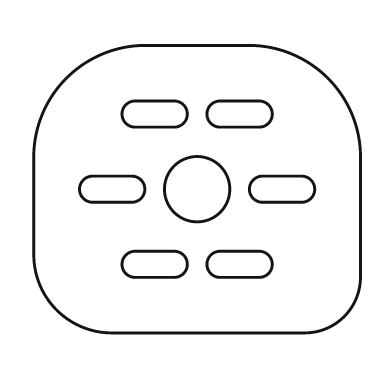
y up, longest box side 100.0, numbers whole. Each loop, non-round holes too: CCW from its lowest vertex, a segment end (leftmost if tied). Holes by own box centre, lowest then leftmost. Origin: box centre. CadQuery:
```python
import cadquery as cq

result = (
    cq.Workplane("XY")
    .moveTo(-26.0, -44.0)
    .lineTo(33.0, -44.0)
    .threePointArc((45.0, -39.0), (50.0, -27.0))
    .lineTo(50.0, 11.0)
    .threePointArc((40.0, 34.0), (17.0, 44.0))
    .lineTo(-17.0, 44.0)
    .threePointArc((-40.0, 34.0), (-50.0, 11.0))
    .lineTo(-50.0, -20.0)
    .threePointArc((-43.0, -37.0), (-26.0, -44.0))
    .close()
    .moveTo(-19.0, -27.0)
    .lineTo(-7.0, -27.0)
    .threePointArc((-3.0, -23.0), (-7.0, -19.0))
    .lineTo(-19.0, -19.0)
    .threePointArc((-23.0, -23.0), (-19.0, -27.0))
    .close()
    .moveTo(7.0, -27.0)
    .lineTo(19.0, -27.0)
    .threePointArc((23.0, -23.0), (19.0, -19.0))
    .lineTo(7.0, -19.0)
    .threePointArc((3.0, -23.0), (7.0, -27.0))
    .close()
    .moveTo(-32.0, -4.0)
    .lineTo(-20.0, -4.0)
    .threePointArc((-16.0, 0.0), (-20.0, 4.0))
    .lineTo(-32.0, 4.0)
    .threePointArc((-36.0, 0.0), (-32.0, -4.0))
    .close()
    .moveTo(0.0, 0.0)
    .circle(10.0)
    .moveTo(20.0, -4.0)
    .lineTo(32.0, -4.0)
    .threePointArc((36.0, 0.0), (32.0, 4.0))
    .lineTo(20.0, 4.0)
    .threePointArc((16.0, 0.0), (20.0, -4.0))
    .close()
    .moveTo(-19.0, 19.0)
    .lineTo(-7.0, 19.0)
    .threePointArc((-3.0, 23.0), (-7.0, 27.0))
    .lineTo(-19.0, 27.0)
    .threePointArc((-23.0, 23.0), (-19.0, 19.0))
    .close()
    .moveTo(7.0, 19.0)
    .lineTo(19.0, 19.0)
    .threePointArc((23.0, 23.0), (19.0, 27.0))
    .lineTo(7.0, 27.0)
    .threePointArc((3.0, 23.0), (7.0, 19.0))
    .close()
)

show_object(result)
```